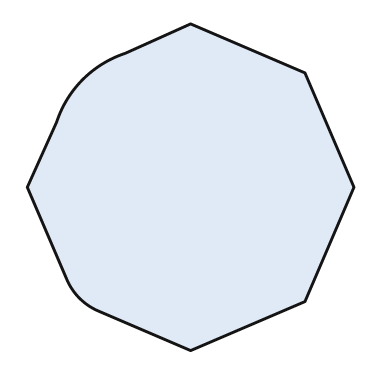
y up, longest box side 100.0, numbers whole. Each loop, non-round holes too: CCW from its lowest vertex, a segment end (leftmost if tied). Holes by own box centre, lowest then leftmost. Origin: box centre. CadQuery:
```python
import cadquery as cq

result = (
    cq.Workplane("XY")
    .moveTo(0.0, -50.0)
    .lineTo(35.0, -35.0)
    .lineTo(50.0, 0.0)
    .lineTo(35.0, 35.0)
    .lineTo(0.0, 50.0)
    .lineTo(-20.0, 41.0)
    .threePointArc((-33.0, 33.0), (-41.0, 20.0))
    .lineTo(-50.0, 0.0)
    .lineTo(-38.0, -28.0)
    .threePointArc((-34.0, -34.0), (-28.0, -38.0))
    .close()
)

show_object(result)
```